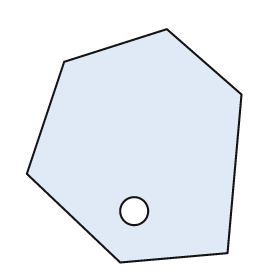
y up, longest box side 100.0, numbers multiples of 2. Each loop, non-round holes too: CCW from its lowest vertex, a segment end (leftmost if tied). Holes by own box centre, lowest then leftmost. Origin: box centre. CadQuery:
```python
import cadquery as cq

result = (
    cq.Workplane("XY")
    .moveTo(-6.0, -50.0)
    .lineTo(40.0, -46.0)
    .lineTo(46.0, 22.0)
    .lineTo(14.0, 50.0)
    .lineTo(-30.0, 36.0)
    .lineTo(-46.0, -12.0)
    .close()
    .moveTo(0.0, -28.0)
    .circle(6.0)
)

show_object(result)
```